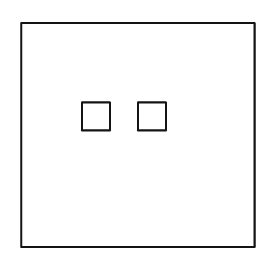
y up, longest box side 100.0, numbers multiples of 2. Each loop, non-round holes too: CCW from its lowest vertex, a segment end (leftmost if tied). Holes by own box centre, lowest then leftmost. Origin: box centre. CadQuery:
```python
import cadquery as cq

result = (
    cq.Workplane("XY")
    .moveTo(-50.0, -48.0)
    .lineTo(50.0, -48.0)
    .lineTo(50.0, 48.0)
    .lineTo(-50.0, 48.0)
    .close()
    .moveTo(-24.0, 2.0)
    .lineTo(-12.0, 2.0)
    .lineTo(-12.0, 14.0)
    .lineTo(-24.0, 14.0)
    .close()
    .moveTo(0.0, 2.0)
    .lineTo(12.0, 2.0)
    .lineTo(12.0, 14.0)
    .lineTo(0.0, 14.0)
    .close()
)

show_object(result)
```